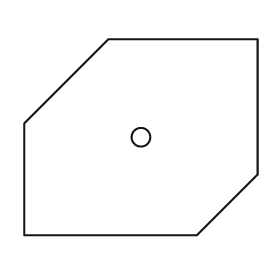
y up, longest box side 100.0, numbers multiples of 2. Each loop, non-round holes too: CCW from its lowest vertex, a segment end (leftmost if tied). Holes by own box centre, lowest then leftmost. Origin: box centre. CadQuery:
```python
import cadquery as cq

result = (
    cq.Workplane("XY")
    .moveTo(-50.0, -42.0)
    .lineTo(24.0, -42.0)
    .lineTo(50.0, -16.0)
    .lineTo(50.0, 42.0)
    .lineTo(-14.0, 42.0)
    .lineTo(-50.0, 6.0)
    .close()
    .moveTo(0.0, 0.0)
    .circle(4.0)
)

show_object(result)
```